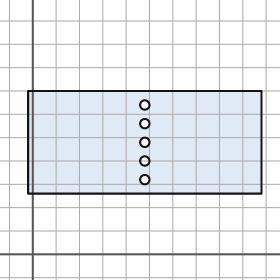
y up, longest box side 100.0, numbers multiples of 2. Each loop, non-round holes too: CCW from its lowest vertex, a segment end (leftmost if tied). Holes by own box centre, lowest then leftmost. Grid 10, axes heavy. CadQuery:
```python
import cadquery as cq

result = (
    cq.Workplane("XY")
    .moveTo(-2.0, 26.0)
    .lineTo(98.0, 26.0)
    .lineTo(98.0, 70.0)
    .lineTo(-2.0, 70.0)
    .close()
    .moveTo(48.0, 32.0)
    .circle(2.0)
    .moveTo(48.0, 40.0)
    .circle(2.0)
    .moveTo(48.0, 48.0)
    .circle(2.0)
    .moveTo(48.0, 56.0)
    .circle(2.0)
    .moveTo(48.0, 64.0)
    .circle(2.0)
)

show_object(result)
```